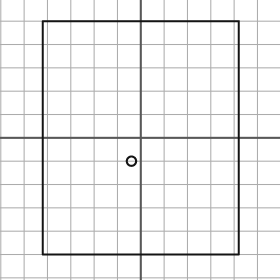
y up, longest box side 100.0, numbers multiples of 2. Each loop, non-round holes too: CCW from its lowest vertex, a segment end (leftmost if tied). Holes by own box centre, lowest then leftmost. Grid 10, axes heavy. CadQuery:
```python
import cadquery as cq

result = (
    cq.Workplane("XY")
    .moveTo(-42.0, -50.0)
    .lineTo(42.0, -50.0)
    .lineTo(42.0, 50.0)
    .lineTo(-42.0, 50.0)
    .close()
    .moveTo(-4.0, -10.0)
    .circle(2.0)
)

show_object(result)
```